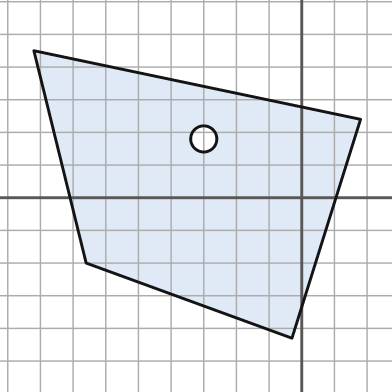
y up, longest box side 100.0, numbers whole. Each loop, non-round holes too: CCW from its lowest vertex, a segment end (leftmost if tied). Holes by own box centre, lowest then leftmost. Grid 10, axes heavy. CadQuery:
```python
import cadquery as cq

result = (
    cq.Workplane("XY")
    .moveTo(-3.0, -43.0)
    .lineTo(18.0, 24.0)
    .lineTo(-82.0, 45.0)
    .lineTo(-66.0, -20.0)
    .close()
    .moveTo(-30.0, 18.0)
    .circle(4.0)
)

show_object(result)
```